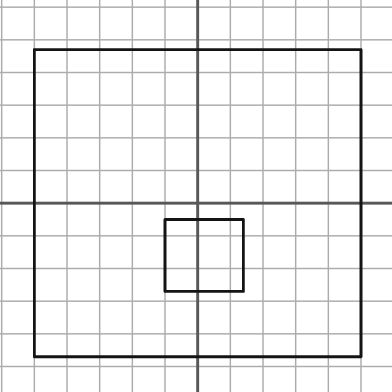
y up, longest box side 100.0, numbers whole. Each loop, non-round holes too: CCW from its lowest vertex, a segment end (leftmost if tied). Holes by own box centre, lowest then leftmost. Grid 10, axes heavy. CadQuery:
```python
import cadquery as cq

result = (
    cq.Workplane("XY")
    .moveTo(-50.0, -47.0)
    .lineTo(50.0, -47.0)
    .lineTo(50.0, 47.0)
    .lineTo(-50.0, 47.0)
    .close()
    .moveTo(-10.0, -27.0)
    .lineTo(14.0, -27.0)
    .lineTo(14.0, -5.0)
    .lineTo(-10.0, -5.0)
    .close()
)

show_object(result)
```